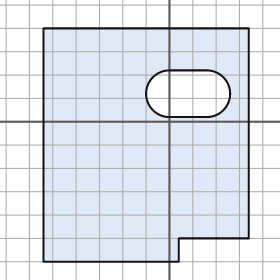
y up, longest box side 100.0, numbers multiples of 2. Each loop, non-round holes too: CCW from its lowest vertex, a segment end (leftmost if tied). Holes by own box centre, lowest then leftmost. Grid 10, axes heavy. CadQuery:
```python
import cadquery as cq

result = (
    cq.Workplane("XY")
    .moveTo(-54.0, -60.0)
    .lineTo(4.0, -60.0)
    .lineTo(4.0, -50.0)
    .lineTo(34.0, -50.0)
    .lineTo(34.0, 40.0)
    .lineTo(-54.0, 40.0)
    .close()
    .moveTo(0.0, 2.0)
    .lineTo(16.0, 2.0)
    .threePointArc((26.0, 12.0), (16.0, 22.0))
    .lineTo(0.0, 22.0)
    .threePointArc((-10.0, 12.0), (0.0, 2.0))
    .close()
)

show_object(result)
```